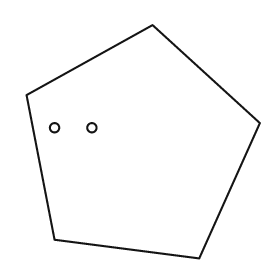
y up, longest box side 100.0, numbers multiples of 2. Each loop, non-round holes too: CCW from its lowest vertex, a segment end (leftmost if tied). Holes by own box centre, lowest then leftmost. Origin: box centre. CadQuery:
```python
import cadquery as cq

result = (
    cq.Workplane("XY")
    .moveTo(24.0, -50.0)
    .lineTo(50.0, 8.0)
    .lineTo(4.0, 50.0)
    .lineTo(-50.0, 20.0)
    .lineTo(-38.0, -42.0)
    .close()
    .moveTo(-38.0, 6.0)
    .circle(2.0)
    .moveTo(-22.0, 6.0)
    .circle(2.0)
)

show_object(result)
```